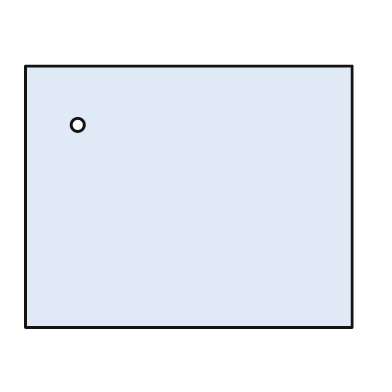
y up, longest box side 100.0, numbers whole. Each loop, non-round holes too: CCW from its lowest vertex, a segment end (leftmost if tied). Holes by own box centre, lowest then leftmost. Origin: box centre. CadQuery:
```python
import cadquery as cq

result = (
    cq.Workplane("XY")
    .moveTo(-50.0, -40.0)
    .lineTo(50.0, -40.0)
    .lineTo(50.0, 40.0)
    .lineTo(-50.0, 40.0)
    .close()
    .moveTo(-34.0, 22.0)
    .circle(2.0)
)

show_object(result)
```